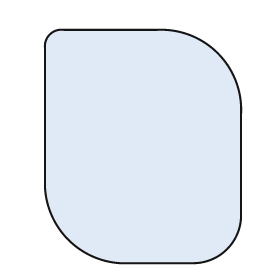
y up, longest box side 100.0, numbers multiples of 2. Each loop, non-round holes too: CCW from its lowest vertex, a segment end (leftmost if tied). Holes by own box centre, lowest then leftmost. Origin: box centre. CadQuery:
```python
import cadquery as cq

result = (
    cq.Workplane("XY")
    .moveTo(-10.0, -50.0)
    .lineTo(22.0, -50.0)
    .threePointArc((36.0, -44.0), (42.0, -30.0))
    .lineTo(42.0, 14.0)
    .threePointArc((32.0, 40.0), (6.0, 50.0))
    .lineTo(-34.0, 50.0)
    .threePointArc((-40.0, 48.0), (-42.0, 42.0))
    .lineTo(-42.0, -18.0)
    .threePointArc((-32.0, -40.0), (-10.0, -50.0))
    .close()
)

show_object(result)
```